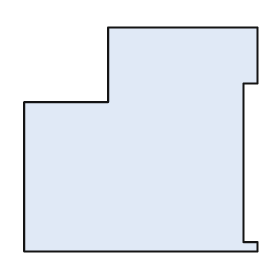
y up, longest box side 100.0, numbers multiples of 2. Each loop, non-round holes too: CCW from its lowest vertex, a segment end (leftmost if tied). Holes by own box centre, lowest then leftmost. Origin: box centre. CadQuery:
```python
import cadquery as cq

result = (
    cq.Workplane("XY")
    .moveTo(-50.0, -48.0)
    .lineTo(50.0, -48.0)
    .lineTo(50.0, -44.0)
    .lineTo(44.0, -44.0)
    .lineTo(44.0, 24.0)
    .lineTo(50.0, 24.0)
    .lineTo(50.0, 48.0)
    .lineTo(-14.0, 48.0)
    .lineTo(-14.0, 16.0)
    .lineTo(-50.0, 16.0)
    .close()
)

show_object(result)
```